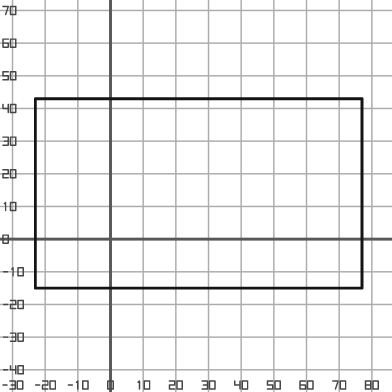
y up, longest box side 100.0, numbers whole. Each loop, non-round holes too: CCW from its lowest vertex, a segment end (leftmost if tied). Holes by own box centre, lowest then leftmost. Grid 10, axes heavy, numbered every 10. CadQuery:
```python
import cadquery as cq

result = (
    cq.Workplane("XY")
    .moveTo(-23.0, -15.0)
    .lineTo(77.0, -15.0)
    .lineTo(77.0, 43.0)
    .lineTo(-23.0, 43.0)
    .close()
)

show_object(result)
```